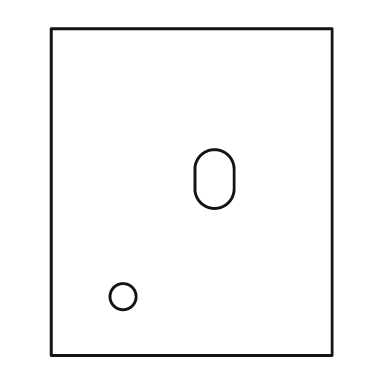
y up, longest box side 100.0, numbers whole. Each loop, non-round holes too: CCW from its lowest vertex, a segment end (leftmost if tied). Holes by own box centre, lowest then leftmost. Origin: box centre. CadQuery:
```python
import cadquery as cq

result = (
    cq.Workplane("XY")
    .moveTo(-43.0, -50.0)
    .lineTo(43.0, -50.0)
    .lineTo(43.0, 50.0)
    .lineTo(-43.0, 50.0)
    .close()
    .moveTo(-21.0, -32.0)
    .circle(4.0)
    .moveTo(1.0, 1.0)
    .threePointArc((7.0, -5.0), (13.0, 1.0))
    .lineTo(13.0, 7.0)
    .threePointArc((7.0, 13.0), (1.0, 7.0))
    .close()
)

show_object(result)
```